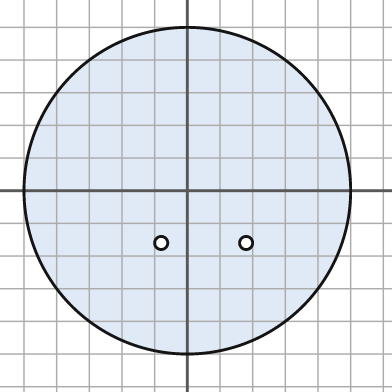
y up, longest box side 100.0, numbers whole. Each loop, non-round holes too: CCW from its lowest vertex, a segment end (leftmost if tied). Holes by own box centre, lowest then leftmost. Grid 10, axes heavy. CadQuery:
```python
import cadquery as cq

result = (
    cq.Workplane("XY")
    .moveTo(0.0, 0.0)
    .circle(50.0)
    .moveTo(-8.0, -16.0)
    .circle(2.0)
    .moveTo(18.0, -16.0)
    .circle(2.0)
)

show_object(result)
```